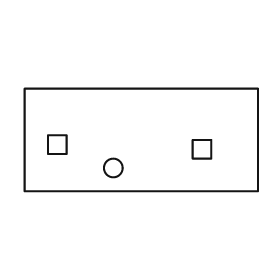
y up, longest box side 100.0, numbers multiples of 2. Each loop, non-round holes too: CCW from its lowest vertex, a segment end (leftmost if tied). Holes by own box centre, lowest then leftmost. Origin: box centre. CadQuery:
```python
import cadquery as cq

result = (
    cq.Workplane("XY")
    .moveTo(-50.0, -22.0)
    .lineTo(50.0, -22.0)
    .lineTo(50.0, 22.0)
    .lineTo(-50.0, 22.0)
    .close()
    .moveTo(-12.0, -12.0)
    .circle(4.0)
    .moveTo(22.0, -8.0)
    .lineTo(30.0, -8.0)
    .lineTo(30.0, 0.0)
    .lineTo(22.0, 0.0)
    .close()
    .moveTo(-40.0, -6.0)
    .lineTo(-32.0, -6.0)
    .lineTo(-32.0, 2.0)
    .lineTo(-40.0, 2.0)
    .close()
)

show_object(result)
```